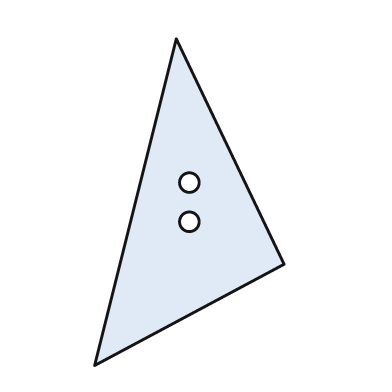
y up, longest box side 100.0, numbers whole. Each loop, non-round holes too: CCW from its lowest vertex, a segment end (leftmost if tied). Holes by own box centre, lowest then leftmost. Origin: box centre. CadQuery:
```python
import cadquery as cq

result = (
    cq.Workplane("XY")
    .moveTo(-29.0, -50.0)
    .lineTo(29.0, -19.0)
    .lineTo(-4.0, 50.0)
    .close()
    .moveTo(0.0, -6.0)
    .circle(3.0)
    .moveTo(0.0, 6.0)
    .circle(3.0)
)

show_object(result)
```